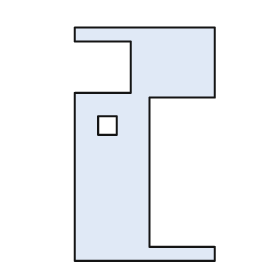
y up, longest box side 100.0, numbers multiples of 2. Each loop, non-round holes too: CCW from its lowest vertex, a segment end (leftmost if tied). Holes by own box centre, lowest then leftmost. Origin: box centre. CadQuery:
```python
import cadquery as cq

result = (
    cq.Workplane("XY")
    .moveTo(-30.0, -50.0)
    .lineTo(30.0, -50.0)
    .lineTo(30.0, -44.0)
    .lineTo(2.0, -44.0)
    .lineTo(2.0, 20.0)
    .lineTo(30.0, 20.0)
    .lineTo(30.0, 50.0)
    .lineTo(-30.0, 50.0)
    .lineTo(-30.0, 44.0)
    .lineTo(-6.0, 44.0)
    .lineTo(-6.0, 22.0)
    .lineTo(-30.0, 22.0)
    .close()
    .moveTo(-20.0, 4.0)
    .lineTo(-12.0, 4.0)
    .lineTo(-12.0, 12.0)
    .lineTo(-20.0, 12.0)
    .close()
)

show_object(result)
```